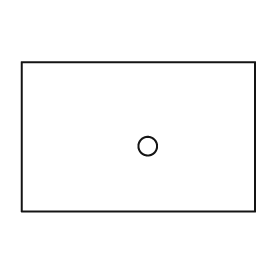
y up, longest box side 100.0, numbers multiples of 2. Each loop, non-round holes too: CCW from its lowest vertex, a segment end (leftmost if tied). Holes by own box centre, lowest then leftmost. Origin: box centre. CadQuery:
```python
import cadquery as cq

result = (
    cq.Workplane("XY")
    .moveTo(-50.0, -32.0)
    .lineTo(50.0, -32.0)
    .lineTo(50.0, 32.0)
    .lineTo(-50.0, 32.0)
    .close()
    .moveTo(4.0, -4.0)
    .circle(4.0)
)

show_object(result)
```